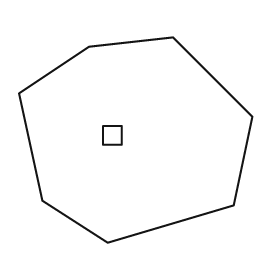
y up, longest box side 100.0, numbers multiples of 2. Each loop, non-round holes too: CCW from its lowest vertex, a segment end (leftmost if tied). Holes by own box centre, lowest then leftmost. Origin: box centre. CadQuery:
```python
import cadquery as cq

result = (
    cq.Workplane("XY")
    .moveTo(-12.0, -44.0)
    .lineTo(42.0, -28.0)
    .lineTo(50.0, 10.0)
    .lineTo(16.0, 44.0)
    .lineTo(-20.0, 40.0)
    .lineTo(-50.0, 20.0)
    .lineTo(-40.0, -26.0)
    .close()
    .moveTo(-14.0, -2.0)
    .lineTo(-6.0, -2.0)
    .lineTo(-6.0, 6.0)
    .lineTo(-14.0, 6.0)
    .close()
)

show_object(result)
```